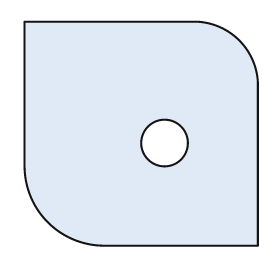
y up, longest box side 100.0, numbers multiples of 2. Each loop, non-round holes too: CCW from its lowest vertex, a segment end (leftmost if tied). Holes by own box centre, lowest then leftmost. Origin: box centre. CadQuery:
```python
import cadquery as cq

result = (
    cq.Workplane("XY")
    .moveTo(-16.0, -48.0)
    .lineTo(50.0, -48.0)
    .lineTo(50.0, 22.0)
    .threePointArc((42.0, 40.0), (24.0, 48.0))
    .lineTo(-50.0, 48.0)
    .lineTo(-50.0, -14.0)
    .threePointArc((-40.0, -38.0), (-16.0, -48.0))
    .close()
    .moveTo(10.0, -4.0)
    .circle(10.0)
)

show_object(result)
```